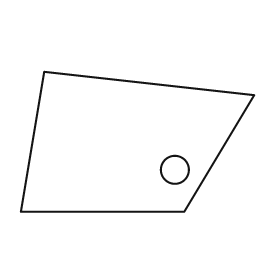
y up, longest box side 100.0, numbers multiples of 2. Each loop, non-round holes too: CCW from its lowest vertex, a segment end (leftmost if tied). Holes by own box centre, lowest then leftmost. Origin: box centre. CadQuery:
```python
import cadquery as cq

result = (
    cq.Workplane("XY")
    .moveTo(-50.0, -30.0)
    .lineTo(20.0, -30.0)
    .lineTo(50.0, 20.0)
    .lineTo(-40.0, 30.0)
    .close()
    .moveTo(16.0, -12.0)
    .circle(6.0)
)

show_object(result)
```